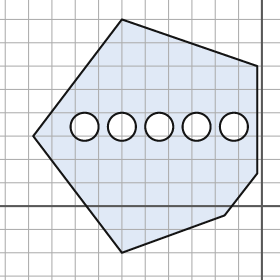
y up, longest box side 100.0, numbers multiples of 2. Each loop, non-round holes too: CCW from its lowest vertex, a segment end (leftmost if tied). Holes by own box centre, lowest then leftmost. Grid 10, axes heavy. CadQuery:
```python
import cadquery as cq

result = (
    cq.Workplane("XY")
    .moveTo(-60.0, -20.0)
    .lineTo(-16.0, -4.0)
    .lineTo(-2.0, 14.0)
    .lineTo(-2.0, 60.0)
    .lineTo(-60.0, 80.0)
    .lineTo(-98.0, 30.0)
    .close()
    .moveTo(-76.0, 34.0)
    .circle(6.0)
    .moveTo(-60.0, 34.0)
    .circle(6.0)
    .moveTo(-44.0, 34.0)
    .circle(6.0)
    .moveTo(-28.0, 34.0)
    .circle(6.0)
    .moveTo(-12.0, 34.0)
    .circle(6.0)
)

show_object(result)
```